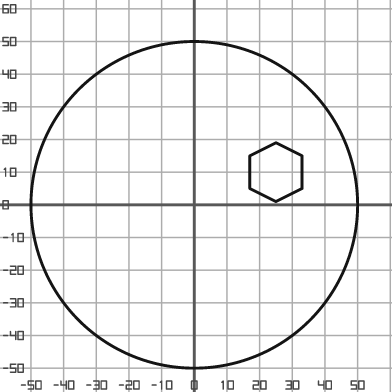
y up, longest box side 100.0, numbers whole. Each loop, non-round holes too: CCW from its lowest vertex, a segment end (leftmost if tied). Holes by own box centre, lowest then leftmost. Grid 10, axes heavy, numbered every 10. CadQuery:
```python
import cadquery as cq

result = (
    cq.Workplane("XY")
    .moveTo(0.0, 0.0)
    .circle(50.0)
    .moveTo(25.0, 1.0)
    .lineTo(33.0, 5.0)
    .lineTo(33.0, 15.0)
    .lineTo(25.0, 19.0)
    .lineTo(17.0, 15.0)
    .lineTo(17.0, 5.0)
    .close()
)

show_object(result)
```